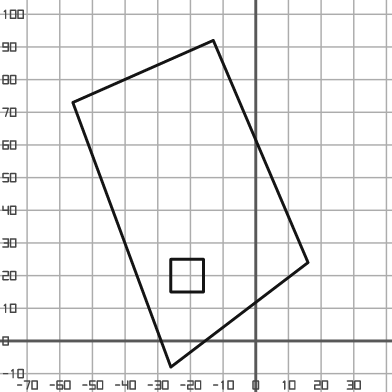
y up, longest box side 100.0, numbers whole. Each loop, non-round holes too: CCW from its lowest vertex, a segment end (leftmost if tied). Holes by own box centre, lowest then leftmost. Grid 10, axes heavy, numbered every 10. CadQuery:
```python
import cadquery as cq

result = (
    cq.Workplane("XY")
    .moveTo(-26.0, -8.0)
    .lineTo(16.0, 24.0)
    .lineTo(-13.0, 92.0)
    .lineTo(-56.0, 73.0)
    .close()
    .moveTo(-26.0, 15.0)
    .lineTo(-16.0, 15.0)
    .lineTo(-16.0, 25.0)
    .lineTo(-26.0, 25.0)
    .close()
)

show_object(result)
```